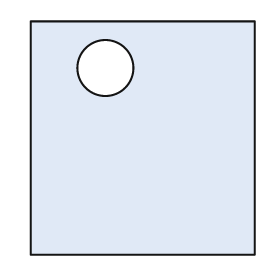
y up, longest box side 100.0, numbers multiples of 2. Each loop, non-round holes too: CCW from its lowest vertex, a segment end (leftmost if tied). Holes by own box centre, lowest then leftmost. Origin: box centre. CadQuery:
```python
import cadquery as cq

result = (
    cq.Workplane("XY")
    .moveTo(-48.0, -50.0)
    .lineTo(48.0, -50.0)
    .lineTo(48.0, 50.0)
    .lineTo(-48.0, 50.0)
    .close()
    .moveTo(-16.0, 30.0)
    .circle(12.0)
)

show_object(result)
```